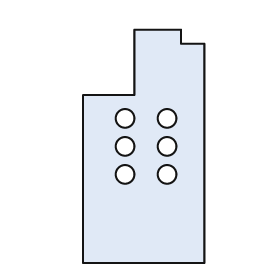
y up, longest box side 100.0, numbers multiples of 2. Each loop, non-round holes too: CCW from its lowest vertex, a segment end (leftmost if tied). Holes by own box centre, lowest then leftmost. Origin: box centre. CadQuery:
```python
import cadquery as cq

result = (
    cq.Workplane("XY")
    .moveTo(-26.0, -50.0)
    .lineTo(26.0, -50.0)
    .lineTo(26.0, 44.0)
    .lineTo(16.0, 44.0)
    .lineTo(16.0, 50.0)
    .lineTo(-4.0, 50.0)
    .lineTo(-4.0, 22.0)
    .lineTo(-26.0, 22.0)
    .close()
    .moveTo(-8.0, -12.0)
    .circle(4.0)
    .moveTo(10.0, -12.0)
    .circle(4.0)
    .moveTo(-8.0, 0.0)
    .circle(4.0)
    .moveTo(10.0, 0.0)
    .circle(4.0)
    .moveTo(-8.0, 12.0)
    .circle(4.0)
    .moveTo(10.0, 12.0)
    .circle(4.0)
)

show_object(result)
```